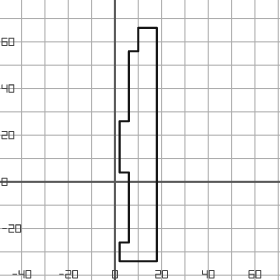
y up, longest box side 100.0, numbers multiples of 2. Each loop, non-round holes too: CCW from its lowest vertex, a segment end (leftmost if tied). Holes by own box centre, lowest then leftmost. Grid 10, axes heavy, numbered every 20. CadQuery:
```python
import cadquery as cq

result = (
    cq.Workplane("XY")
    .moveTo(2.0, -34.0)
    .lineTo(18.0, -34.0)
    .lineTo(18.0, 66.0)
    .lineTo(10.0, 66.0)
    .lineTo(10.0, 56.0)
    .lineTo(6.0, 56.0)
    .lineTo(6.0, 26.0)
    .lineTo(2.0, 26.0)
    .lineTo(2.0, 4.0)
    .lineTo(6.0, 4.0)
    .lineTo(6.0, -26.0)
    .lineTo(2.0, -26.0)
    .close()
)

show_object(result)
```